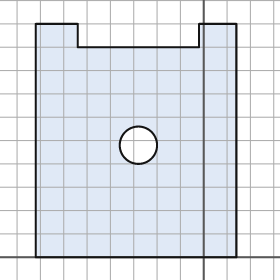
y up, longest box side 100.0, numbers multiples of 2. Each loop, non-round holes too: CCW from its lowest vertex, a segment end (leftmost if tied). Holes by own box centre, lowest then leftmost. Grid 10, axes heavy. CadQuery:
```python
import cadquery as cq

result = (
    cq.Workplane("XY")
    .moveTo(-72.0, 0.0)
    .lineTo(14.0, 0.0)
    .lineTo(14.0, 100.0)
    .lineTo(-2.0, 100.0)
    .lineTo(-2.0, 90.0)
    .lineTo(-54.0, 90.0)
    .lineTo(-54.0, 100.0)
    .lineTo(-72.0, 100.0)
    .close()
    .moveTo(-28.0, 48.0)
    .circle(8.0)
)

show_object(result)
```